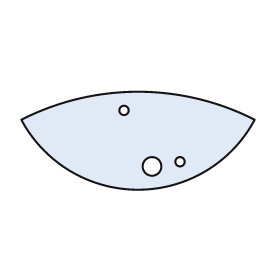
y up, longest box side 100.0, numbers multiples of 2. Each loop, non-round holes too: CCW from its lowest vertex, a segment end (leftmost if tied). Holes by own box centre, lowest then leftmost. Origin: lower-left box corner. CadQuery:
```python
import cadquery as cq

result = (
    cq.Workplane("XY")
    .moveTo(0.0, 30.0)
    .threePointArc((50.0, 0.0), (100.0, 30.0))
    .threePointArc((50.0, 42.0), (0.0, 30.0))
    .close()
    .moveTo(56.0, 10.0)
    .circle(4.0)
    .moveTo(68.0, 12.0)
    .circle(2.0)
    .moveTo(44.0, 34.0)
    .circle(2.0)
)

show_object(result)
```